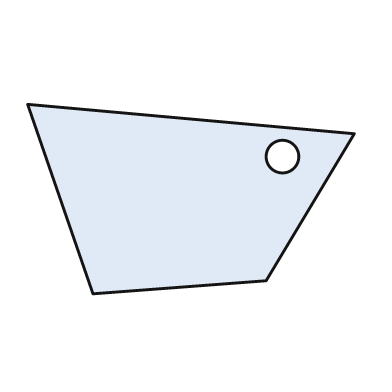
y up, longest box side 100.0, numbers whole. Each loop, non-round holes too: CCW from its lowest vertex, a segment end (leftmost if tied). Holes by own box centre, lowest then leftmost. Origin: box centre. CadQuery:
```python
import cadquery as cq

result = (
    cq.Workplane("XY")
    .moveTo(-30.0, -29.0)
    .lineTo(23.0, -25.0)
    .lineTo(50.0, 20.0)
    .lineTo(-50.0, 29.0)
    .close()
    .moveTo(28.0, 13.0)
    .circle(5.0)
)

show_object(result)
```